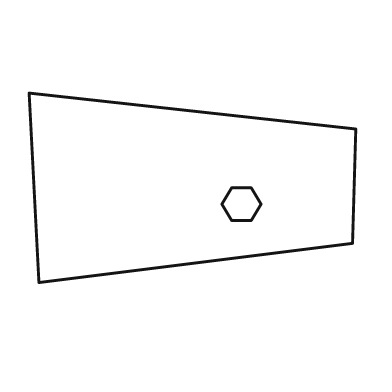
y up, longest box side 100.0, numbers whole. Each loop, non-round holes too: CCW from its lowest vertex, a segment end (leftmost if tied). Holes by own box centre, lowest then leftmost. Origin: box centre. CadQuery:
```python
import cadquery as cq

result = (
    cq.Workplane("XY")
    .moveTo(-47.0, -29.0)
    .lineTo(49.0, -17.0)
    .lineTo(50.0, 18.0)
    .lineTo(-50.0, 29.0)
    .close()
    .moveTo(12.0, -10.0)
    .lineTo(18.0, -10.0)
    .lineTo(21.0, -5.0)
    .lineTo(18.0, 0.0)
    .lineTo(12.0, 0.0)
    .lineTo(9.0, -5.0)
    .close()
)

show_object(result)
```